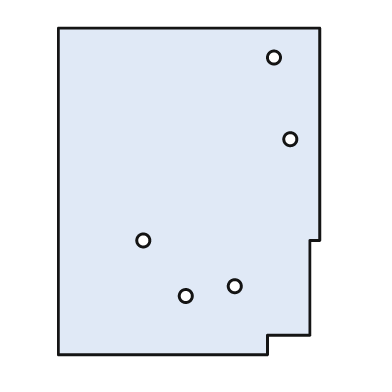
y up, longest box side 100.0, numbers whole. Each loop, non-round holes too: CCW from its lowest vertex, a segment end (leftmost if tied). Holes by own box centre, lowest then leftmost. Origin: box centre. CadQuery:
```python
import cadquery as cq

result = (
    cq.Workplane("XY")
    .moveTo(-40.0, -50.0)
    .lineTo(24.0, -50.0)
    .lineTo(24.0, -44.0)
    .lineTo(37.0, -44.0)
    .lineTo(37.0, -15.0)
    .lineTo(40.0, -15.0)
    .lineTo(40.0, 50.0)
    .lineTo(-40.0, 50.0)
    .close()
    .moveTo(-1.0, -32.0)
    .circle(2.0)
    .moveTo(14.0, -29.0)
    .circle(2.0)
    .moveTo(-14.0, -15.0)
    .circle(2.0)
    .moveTo(31.0, 16.0)
    .circle(2.0)
    .moveTo(26.0, 41.0)
    .circle(2.0)
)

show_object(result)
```